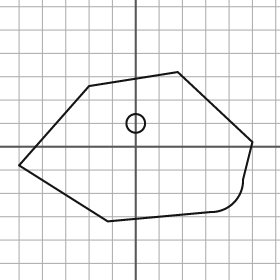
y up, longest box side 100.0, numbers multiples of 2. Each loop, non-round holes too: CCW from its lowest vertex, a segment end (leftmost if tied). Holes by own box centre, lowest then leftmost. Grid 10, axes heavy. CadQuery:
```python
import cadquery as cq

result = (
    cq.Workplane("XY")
    .moveTo(-12.0, -32.0)
    .lineTo(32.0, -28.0)
    .threePointArc((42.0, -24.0), (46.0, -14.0))
    .lineTo(50.0, 2.0)
    .lineTo(18.0, 32.0)
    .lineTo(-20.0, 26.0)
    .lineTo(-50.0, -8.0)
    .close()
    .moveTo(0.0, 10.0)
    .circle(4.0)
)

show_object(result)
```